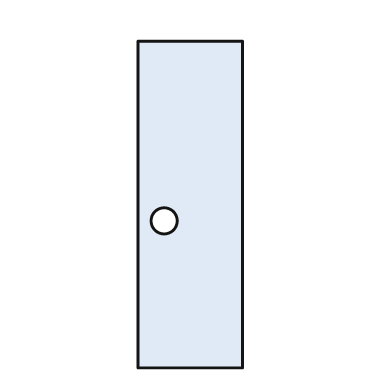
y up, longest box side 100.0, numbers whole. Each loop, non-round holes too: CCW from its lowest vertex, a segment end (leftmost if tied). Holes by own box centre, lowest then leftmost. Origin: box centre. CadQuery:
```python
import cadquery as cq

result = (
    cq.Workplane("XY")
    .moveTo(-16.0, -50.0)
    .lineTo(16.0, -50.0)
    .lineTo(16.0, 50.0)
    .lineTo(-16.0, 50.0)
    .close()
    .moveTo(-8.0, -5.0)
    .circle(4.0)
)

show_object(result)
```